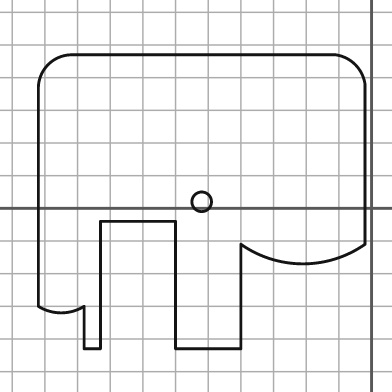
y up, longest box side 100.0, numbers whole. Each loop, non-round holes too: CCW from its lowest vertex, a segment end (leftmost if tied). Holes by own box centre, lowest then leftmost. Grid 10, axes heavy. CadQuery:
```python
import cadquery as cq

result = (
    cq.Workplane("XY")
    .moveTo(-88.0, -43.0)
    .lineTo(-83.0, -43.0)
    .lineTo(-83.0, -4.0)
    .lineTo(-60.0, -4.0)
    .lineTo(-60.0, -43.0)
    .lineTo(-40.0, -43.0)
    .lineTo(-40.0, -11.0)
    .threePointArc((-21.0, -17.0), (-2.0, -11.0))
    .lineTo(-2.0, 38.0)
    .threePointArc((-5.0, 44.0), (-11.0, 47.0))
    .lineTo(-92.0, 47.0)
    .threePointArc((-99.0, 44.0), (-102.0, 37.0))
    .lineTo(-102.0, -30.0)
    .threePointArc((-95.0, -32.0), (-88.0, -30.0))
    .close()
    .moveTo(-52.0, 2.0)
    .circle(3.0)
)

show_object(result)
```